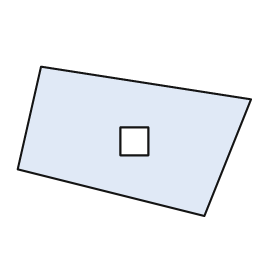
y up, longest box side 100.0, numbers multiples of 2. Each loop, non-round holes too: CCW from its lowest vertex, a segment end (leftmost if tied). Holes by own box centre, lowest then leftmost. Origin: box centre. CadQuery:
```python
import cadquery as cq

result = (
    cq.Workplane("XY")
    .moveTo(30.0, -32.0)
    .lineTo(50.0, 18.0)
    .lineTo(-40.0, 32.0)
    .lineTo(-50.0, -12.0)
    .close()
    .moveTo(-6.0, -6.0)
    .lineTo(6.0, -6.0)
    .lineTo(6.0, 6.0)
    .lineTo(-6.0, 6.0)
    .close()
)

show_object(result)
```